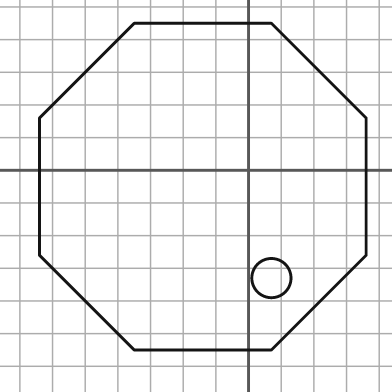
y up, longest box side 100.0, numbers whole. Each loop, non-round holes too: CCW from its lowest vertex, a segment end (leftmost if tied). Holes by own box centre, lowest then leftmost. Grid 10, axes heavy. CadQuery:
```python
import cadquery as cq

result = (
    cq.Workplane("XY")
    .moveTo(-35.0, -55.0)
    .lineTo(7.0, -55.0)
    .lineTo(36.0, -26.0)
    .lineTo(36.0, 16.0)
    .lineTo(7.0, 45.0)
    .lineTo(-35.0, 45.0)
    .lineTo(-64.0, 16.0)
    .lineTo(-64.0, -26.0)
    .close()
    .moveTo(7.0, -33.0)
    .circle(6.0)
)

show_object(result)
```